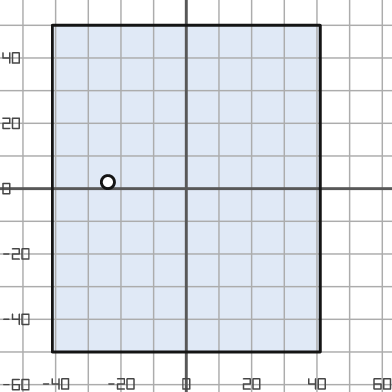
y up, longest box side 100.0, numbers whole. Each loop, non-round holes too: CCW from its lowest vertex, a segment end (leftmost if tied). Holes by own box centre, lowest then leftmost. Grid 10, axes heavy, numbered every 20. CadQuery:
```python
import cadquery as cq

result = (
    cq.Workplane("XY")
    .moveTo(-41.0, -50.0)
    .lineTo(41.0, -50.0)
    .lineTo(41.0, 50.0)
    .lineTo(-41.0, 50.0)
    .close()
    .moveTo(-24.0, 2.0)
    .circle(2.0)
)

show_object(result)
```